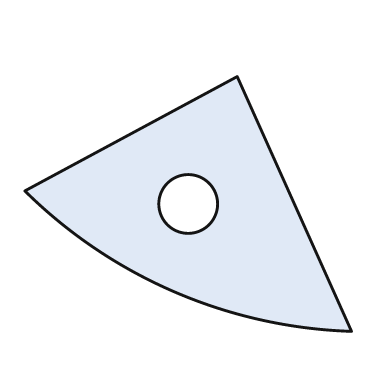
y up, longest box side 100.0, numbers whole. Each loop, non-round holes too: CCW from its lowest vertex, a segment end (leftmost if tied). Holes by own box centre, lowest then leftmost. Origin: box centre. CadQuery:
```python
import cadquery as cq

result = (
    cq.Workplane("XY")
    .moveTo(50.0, -39.0)
    .lineTo(15.0, 39.0)
    .lineTo(-50.0, 4.0)
    .threePointArc((-4.0, -27.0), (50.0, -39.0))
    .close()
    .moveTo(0.0, 0.0)
    .circle(9.0)
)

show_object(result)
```